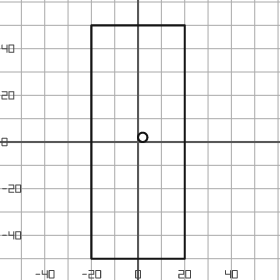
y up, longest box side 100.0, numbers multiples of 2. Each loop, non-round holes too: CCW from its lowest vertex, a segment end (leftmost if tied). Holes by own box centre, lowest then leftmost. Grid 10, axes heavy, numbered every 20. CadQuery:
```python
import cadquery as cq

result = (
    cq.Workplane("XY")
    .moveTo(-20.0, -50.0)
    .lineTo(20.0, -50.0)
    .lineTo(20.0, 50.0)
    .lineTo(-20.0, 50.0)
    .close()
    .moveTo(2.0, 2.0)
    .circle(2.0)
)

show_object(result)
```